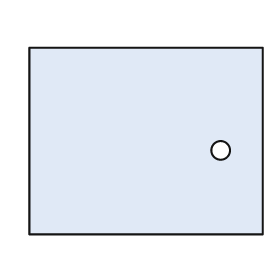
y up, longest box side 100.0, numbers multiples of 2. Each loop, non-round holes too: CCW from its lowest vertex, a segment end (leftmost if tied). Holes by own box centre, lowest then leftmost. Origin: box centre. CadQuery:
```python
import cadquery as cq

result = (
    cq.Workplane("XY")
    .moveTo(-50.0, -40.0)
    .lineTo(50.0, -40.0)
    .lineTo(50.0, 40.0)
    .lineTo(-50.0, 40.0)
    .close()
    .moveTo(32.0, -4.0)
    .circle(4.0)
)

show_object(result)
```